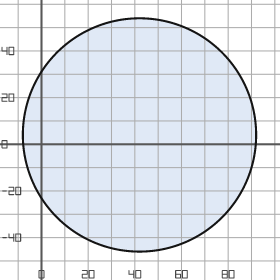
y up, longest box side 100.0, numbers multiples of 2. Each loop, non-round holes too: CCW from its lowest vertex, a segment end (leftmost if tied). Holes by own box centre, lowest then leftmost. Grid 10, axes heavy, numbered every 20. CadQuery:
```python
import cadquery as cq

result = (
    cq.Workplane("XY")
    .moveTo(42.0, 4.0)
    .circle(50.0)
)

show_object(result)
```